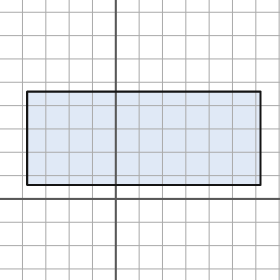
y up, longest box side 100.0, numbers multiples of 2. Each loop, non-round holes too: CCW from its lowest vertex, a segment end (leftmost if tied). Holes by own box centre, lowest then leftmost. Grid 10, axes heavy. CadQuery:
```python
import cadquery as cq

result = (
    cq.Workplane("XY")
    .moveTo(-38.0, 6.0)
    .lineTo(62.0, 6.0)
    .lineTo(62.0, 46.0)
    .lineTo(-38.0, 46.0)
    .close()
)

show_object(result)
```